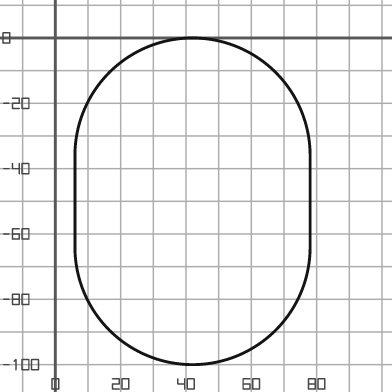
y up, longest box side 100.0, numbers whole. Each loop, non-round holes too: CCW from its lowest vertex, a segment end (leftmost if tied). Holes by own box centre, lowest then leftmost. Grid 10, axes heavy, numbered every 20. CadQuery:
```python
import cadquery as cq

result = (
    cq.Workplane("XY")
    .moveTo(6.0, -64.0)
    .threePointArc((42.0, -100.0), (78.0, -64.0))
    .lineTo(78.0, -36.0)
    .threePointArc((42.0, 0.0), (6.0, -36.0))
    .close()
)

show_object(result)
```